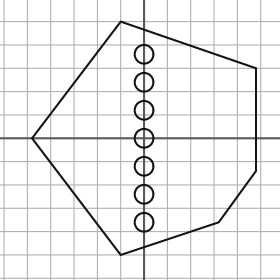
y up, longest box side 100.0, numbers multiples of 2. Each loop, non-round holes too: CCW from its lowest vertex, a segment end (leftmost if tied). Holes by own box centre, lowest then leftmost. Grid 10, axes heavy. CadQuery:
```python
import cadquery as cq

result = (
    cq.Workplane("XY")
    .moveTo(-10.0, -50.0)
    .lineTo(32.0, -36.0)
    .lineTo(48.0, -14.0)
    .lineTo(48.0, 30.0)
    .lineTo(-10.0, 50.0)
    .lineTo(-48.0, 0.0)
    .close()
    .moveTo(0.0, -36.0)
    .circle(4.0)
    .moveTo(0.0, -24.0)
    .circle(4.0)
    .moveTo(0.0, -12.0)
    .circle(4.0)
    .moveTo(0.0, 0.0)
    .circle(4.0)
    .moveTo(0.0, 12.0)
    .circle(4.0)
    .moveTo(0.0, 24.0)
    .circle(4.0)
    .moveTo(0.0, 36.0)
    .circle(4.0)
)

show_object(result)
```